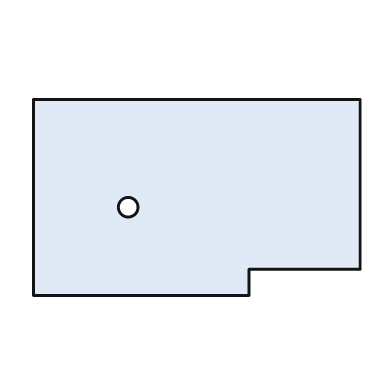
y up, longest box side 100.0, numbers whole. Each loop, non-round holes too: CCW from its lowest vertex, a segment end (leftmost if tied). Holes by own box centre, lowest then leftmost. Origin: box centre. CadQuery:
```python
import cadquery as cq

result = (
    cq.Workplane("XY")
    .moveTo(-50.0, -30.0)
    .lineTo(16.0, -30.0)
    .lineTo(16.0, -22.0)
    .lineTo(50.0, -22.0)
    .lineTo(50.0, 30.0)
    .lineTo(-50.0, 30.0)
    .close()
    .moveTo(-21.0, -3.0)
    .circle(3.0)
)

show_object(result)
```